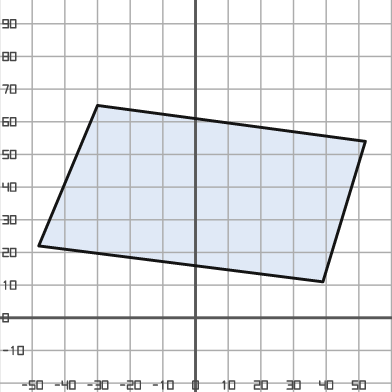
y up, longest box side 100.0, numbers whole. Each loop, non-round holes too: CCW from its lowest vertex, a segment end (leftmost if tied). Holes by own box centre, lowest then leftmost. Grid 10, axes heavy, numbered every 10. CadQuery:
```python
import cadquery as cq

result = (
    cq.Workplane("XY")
    .moveTo(39.0, 11.0)
    .lineTo(52.0, 54.0)
    .lineTo(-30.0, 65.0)
    .lineTo(-48.0, 22.0)
    .close()
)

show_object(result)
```